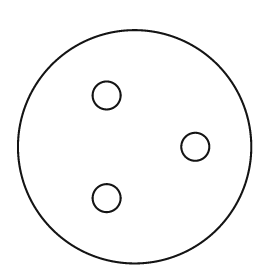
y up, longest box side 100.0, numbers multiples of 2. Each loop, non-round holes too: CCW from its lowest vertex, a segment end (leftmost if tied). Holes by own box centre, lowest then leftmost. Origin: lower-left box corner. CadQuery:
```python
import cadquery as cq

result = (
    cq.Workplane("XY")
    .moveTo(50.0, 50.0)
    .circle(50.0)
    .moveTo(38.0, 28.0)
    .circle(6.0)
    .moveTo(76.0, 50.0)
    .circle(6.0)
    .moveTo(38.0, 72.0)
    .circle(6.0)
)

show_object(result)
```